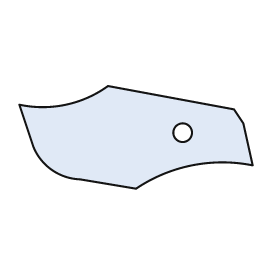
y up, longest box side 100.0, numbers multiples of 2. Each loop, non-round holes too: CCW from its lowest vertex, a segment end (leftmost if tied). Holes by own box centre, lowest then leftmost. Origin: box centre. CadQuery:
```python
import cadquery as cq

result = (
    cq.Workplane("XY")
    .moveTo(0.0, -22.0)
    .threePointArc((24.0, -12.0), (50.0, -12.0))
    .lineTo(46.0, 6.0)
    .lineTo(42.0, 12.0)
    .lineTo(-12.0, 22.0)
    .threePointArc((-30.0, 14.0), (-50.0, 14.0))
    .lineTo(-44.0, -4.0)
    .threePointArc((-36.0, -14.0), (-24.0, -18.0))
    .close()
    .moveTo(20.0, 2.0)
    .circle(4.0)
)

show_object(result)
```